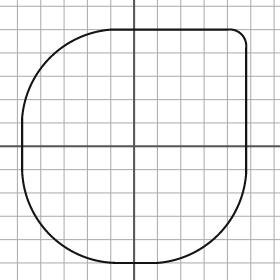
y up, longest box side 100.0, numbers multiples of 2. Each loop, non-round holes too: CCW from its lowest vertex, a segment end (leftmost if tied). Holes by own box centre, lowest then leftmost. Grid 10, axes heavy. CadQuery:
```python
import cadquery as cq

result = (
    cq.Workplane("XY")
    .moveTo(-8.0, -50.0)
    .lineTo(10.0, -50.0)
    .threePointArc((36.0, -38.0), (48.0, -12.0))
    .lineTo(48.0, 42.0)
    .threePointArc((46.0, 48.0), (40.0, 50.0))
    .lineTo(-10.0, 50.0)
    .threePointArc((-36.0, 38.0), (-48.0, 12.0))
    .lineTo(-48.0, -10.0)
    .threePointArc((-36.0, -38.0), (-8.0, -50.0))
    .close()
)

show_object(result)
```